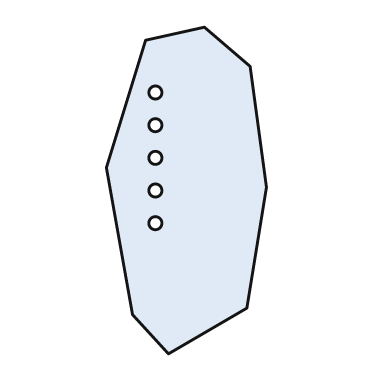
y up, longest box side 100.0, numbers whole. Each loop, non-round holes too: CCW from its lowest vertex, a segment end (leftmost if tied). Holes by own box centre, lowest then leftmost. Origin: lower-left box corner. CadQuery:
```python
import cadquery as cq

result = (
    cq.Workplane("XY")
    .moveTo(19.0, 0.0)
    .lineTo(43.0, 14.0)
    .lineTo(49.0, 51.0)
    .lineTo(44.0, 88.0)
    .lineTo(30.0, 100.0)
    .lineTo(12.0, 96.0)
    .lineTo(0.0, 57.0)
    .lineTo(8.0, 12.0)
    .close()
    .moveTo(15.0, 40.0)
    .circle(2.0)
    .moveTo(15.0, 50.0)
    .circle(2.0)
    .moveTo(15.0, 60.0)
    .circle(2.0)
    .moveTo(15.0, 70.0)
    .circle(2.0)
    .moveTo(15.0, 80.0)
    .circle(2.0)
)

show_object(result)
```